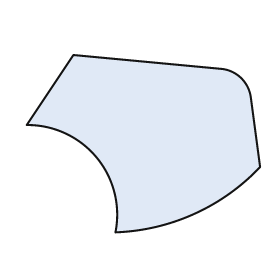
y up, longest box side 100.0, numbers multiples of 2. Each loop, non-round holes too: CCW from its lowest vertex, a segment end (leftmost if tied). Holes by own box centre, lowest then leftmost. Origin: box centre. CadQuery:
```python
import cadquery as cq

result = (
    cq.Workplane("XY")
    .moveTo(-12.0, -38.0)
    .threePointArc((22.0, -30.0), (50.0, -10.0))
    .lineTo(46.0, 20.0)
    .threePointArc((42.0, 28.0), (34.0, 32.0))
    .lineTo(-30.0, 38.0)
    .lineTo(-50.0, 8.0)
    .threePointArc((-20.0, -6.0), (-12.0, -38.0))
    .close()
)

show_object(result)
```